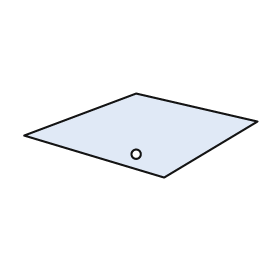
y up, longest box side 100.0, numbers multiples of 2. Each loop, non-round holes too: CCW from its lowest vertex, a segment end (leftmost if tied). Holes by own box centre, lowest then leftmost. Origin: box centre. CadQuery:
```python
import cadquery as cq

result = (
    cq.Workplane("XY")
    .moveTo(10.0, -18.0)
    .lineTo(50.0, 6.0)
    .lineTo(-2.0, 18.0)
    .lineTo(-50.0, 0.0)
    .close()
    .moveTo(-2.0, -8.0)
    .circle(2.0)
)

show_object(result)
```